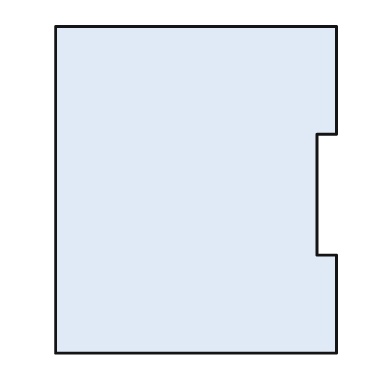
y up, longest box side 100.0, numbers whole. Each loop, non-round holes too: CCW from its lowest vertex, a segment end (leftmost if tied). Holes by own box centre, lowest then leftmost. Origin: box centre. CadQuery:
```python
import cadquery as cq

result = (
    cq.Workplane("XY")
    .moveTo(-43.0, -50.0)
    .lineTo(43.0, -50.0)
    .lineTo(43.0, -20.0)
    .lineTo(37.0, -20.0)
    .lineTo(37.0, 17.0)
    .lineTo(43.0, 17.0)
    .lineTo(43.0, 50.0)
    .lineTo(-43.0, 50.0)
    .close()
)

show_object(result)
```